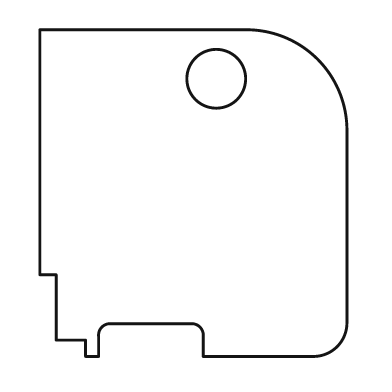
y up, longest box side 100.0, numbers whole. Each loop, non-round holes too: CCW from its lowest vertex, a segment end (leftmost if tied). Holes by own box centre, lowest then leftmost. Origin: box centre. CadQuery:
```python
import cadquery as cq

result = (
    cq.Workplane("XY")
    .moveTo(-33.0, -50.0)
    .lineTo(-29.0, -50.0)
    .lineTo(-29.0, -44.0)
    .threePointArc((-28.0, -41.0), (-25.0, -40.0))
    .lineTo(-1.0, -40.0)
    .threePointArc((2.0, -41.0), (3.0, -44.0))
    .lineTo(3.0, -50.0)
    .lineTo(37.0, -50.0)
    .threePointArc((44.0, -47.0), (47.0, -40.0))
    .lineTo(47.0, 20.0)
    .threePointArc((38.0, 41.0), (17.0, 50.0))
    .lineTo(-47.0, 50.0)
    .lineTo(-47.0, -25.0)
    .lineTo(-42.0, -25.0)
    .lineTo(-42.0, -45.0)
    .lineTo(-33.0, -45.0)
    .close()
    .moveTo(7.0, 35.0)
    .circle(9.0)
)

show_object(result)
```